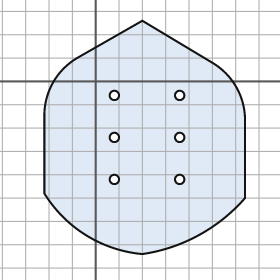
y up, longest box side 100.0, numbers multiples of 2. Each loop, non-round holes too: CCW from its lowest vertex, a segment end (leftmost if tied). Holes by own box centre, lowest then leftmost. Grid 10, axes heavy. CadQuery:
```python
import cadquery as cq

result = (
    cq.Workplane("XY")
    .moveTo(20.0, -74.0)
    .threePointArc((44.0, -66.0), (64.0, -50.0))
    .lineTo(64.0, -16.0)
    .threePointArc((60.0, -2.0), (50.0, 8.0))
    .lineTo(20.0, 26.0)
    .lineTo(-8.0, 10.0)
    .threePointArc((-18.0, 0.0), (-22.0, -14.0))
    .lineTo(-22.0, -48.0)
    .threePointArc((-4.0, -66.0), (20.0, -74.0))
    .close()
    .moveTo(8.0, -42.0)
    .circle(2.0)
    .moveTo(36.0, -42.0)
    .circle(2.0)
    .moveTo(8.0, -24.0)
    .circle(2.0)
    .moveTo(36.0, -24.0)
    .circle(2.0)
    .moveTo(8.0, -6.0)
    .circle(2.0)
    .moveTo(36.0, -6.0)
    .circle(2.0)
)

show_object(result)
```